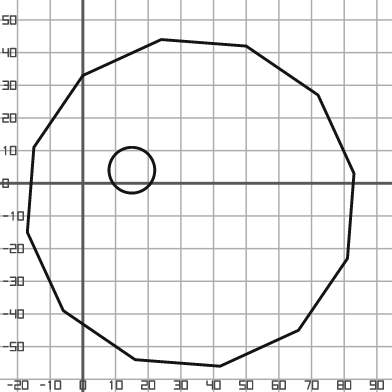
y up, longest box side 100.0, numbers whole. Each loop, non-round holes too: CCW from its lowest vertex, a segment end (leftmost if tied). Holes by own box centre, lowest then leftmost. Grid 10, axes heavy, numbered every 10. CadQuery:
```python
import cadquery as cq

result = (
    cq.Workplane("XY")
    .moveTo(42.0, -56.0)
    .lineTo(66.0, -45.0)
    .lineTo(81.0, -23.0)
    .lineTo(83.0, 3.0)
    .lineTo(72.0, 27.0)
    .lineTo(50.0, 42.0)
    .lineTo(24.0, 44.0)
    .lineTo(0.0, 33.0)
    .lineTo(-15.0, 11.0)
    .lineTo(-17.0, -15.0)
    .lineTo(-6.0, -39.0)
    .lineTo(16.0, -54.0)
    .close()
    .moveTo(15.0, 4.0)
    .circle(7.0)
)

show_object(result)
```